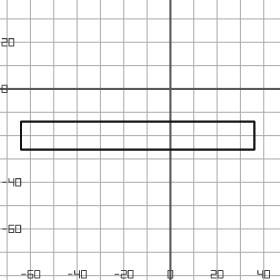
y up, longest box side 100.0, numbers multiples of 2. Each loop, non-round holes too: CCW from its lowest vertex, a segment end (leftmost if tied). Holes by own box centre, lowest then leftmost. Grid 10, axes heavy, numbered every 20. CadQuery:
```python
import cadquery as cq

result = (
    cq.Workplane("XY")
    .moveTo(-64.0, -26.0)
    .lineTo(36.0, -26.0)
    .lineTo(36.0, -14.0)
    .lineTo(-64.0, -14.0)
    .close()
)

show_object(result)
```